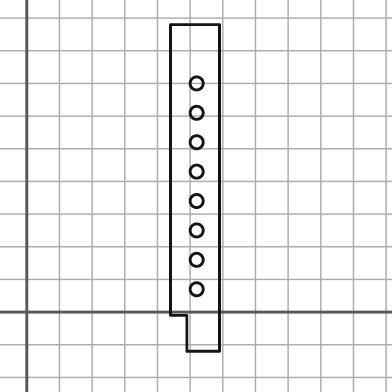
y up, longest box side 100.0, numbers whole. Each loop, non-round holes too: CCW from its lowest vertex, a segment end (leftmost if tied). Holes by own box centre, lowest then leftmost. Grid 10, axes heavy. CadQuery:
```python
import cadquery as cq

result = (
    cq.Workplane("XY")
    .moveTo(49.0, -12.0)
    .lineTo(59.0, -12.0)
    .lineTo(59.0, 88.0)
    .lineTo(44.0, 88.0)
    .lineTo(44.0, -1.0)
    .lineTo(49.0, -1.0)
    .close()
    .moveTo(52.0, 7.0)
    .circle(2.0)
    .moveTo(52.0, 16.0)
    .circle(2.0)
    .moveTo(52.0, 25.0)
    .circle(2.0)
    .moveTo(52.0, 34.0)
    .circle(2.0)
    .moveTo(52.0, 43.0)
    .circle(2.0)
    .moveTo(52.0, 52.0)
    .circle(2.0)
    .moveTo(52.0, 61.0)
    .circle(2.0)
    .moveTo(52.0, 70.0)
    .circle(2.0)
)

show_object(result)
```